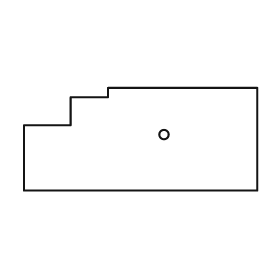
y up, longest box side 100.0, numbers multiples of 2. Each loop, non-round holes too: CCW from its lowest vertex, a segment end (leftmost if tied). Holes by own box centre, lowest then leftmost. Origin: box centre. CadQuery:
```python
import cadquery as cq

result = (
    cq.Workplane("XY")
    .moveTo(-50.0, -22.0)
    .lineTo(50.0, -22.0)
    .lineTo(50.0, 22.0)
    .lineTo(-14.0, 22.0)
    .lineTo(-14.0, 18.0)
    .lineTo(-30.0, 18.0)
    .lineTo(-30.0, 6.0)
    .lineTo(-50.0, 6.0)
    .close()
    .moveTo(10.0, 2.0)
    .circle(2.0)
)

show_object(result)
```